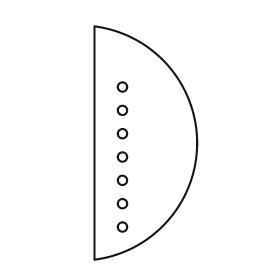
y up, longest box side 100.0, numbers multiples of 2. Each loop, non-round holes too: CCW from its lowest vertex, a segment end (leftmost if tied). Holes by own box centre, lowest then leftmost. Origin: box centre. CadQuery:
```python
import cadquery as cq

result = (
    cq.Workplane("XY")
    .moveTo(-22.0, -50.0)
    .threePointArc((22.0, 0.0), (-22.0, 50.0))
    .close()
    .moveTo(-10.0, -36.0)
    .circle(2.0)
    .moveTo(-10.0, -26.0)
    .circle(2.0)
    .moveTo(-10.0, -16.0)
    .circle(2.0)
    .moveTo(-10.0, -6.0)
    .circle(2.0)
    .moveTo(-10.0, 4.0)
    .circle(2.0)
    .moveTo(-10.0, 14.0)
    .circle(2.0)
    .moveTo(-10.0, 24.0)
    .circle(2.0)
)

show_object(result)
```